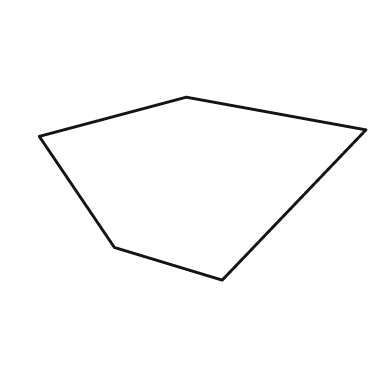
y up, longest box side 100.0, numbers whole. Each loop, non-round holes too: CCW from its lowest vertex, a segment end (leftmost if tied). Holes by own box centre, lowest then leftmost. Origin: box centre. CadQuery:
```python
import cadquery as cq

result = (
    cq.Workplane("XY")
    .moveTo(6.0, -28.0)
    .lineTo(50.0, 18.0)
    .lineTo(-5.0, 28.0)
    .lineTo(-50.0, 16.0)
    .lineTo(-27.0, -18.0)
    .close()
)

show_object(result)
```